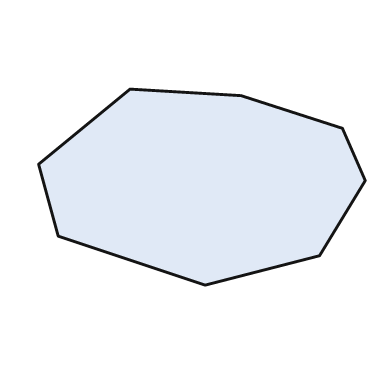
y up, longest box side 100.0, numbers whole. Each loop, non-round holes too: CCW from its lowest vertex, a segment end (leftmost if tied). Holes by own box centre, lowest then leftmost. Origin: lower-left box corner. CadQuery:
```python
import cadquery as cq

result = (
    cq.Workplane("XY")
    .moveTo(51.0, 0.0)
    .lineTo(86.0, 9.0)
    .lineTo(100.0, 32.0)
    .lineTo(93.0, 48.0)
    .lineTo(62.0, 58.0)
    .lineTo(28.0, 60.0)
    .lineTo(0.0, 37.0)
    .lineTo(6.0, 15.0)
    .close()
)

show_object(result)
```